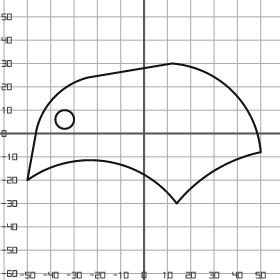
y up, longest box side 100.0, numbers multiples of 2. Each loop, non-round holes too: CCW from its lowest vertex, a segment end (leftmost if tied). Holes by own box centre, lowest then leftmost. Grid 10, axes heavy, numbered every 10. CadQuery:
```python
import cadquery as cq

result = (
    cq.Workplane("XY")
    .moveTo(14.0, -30.0)
    .threePointArc((30.0, -16.0), (50.0, -8.0))
    .threePointArc((38.0, 18.0), (12.0, 30.0))
    .lineTo(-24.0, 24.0)
    .threePointArc((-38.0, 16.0), (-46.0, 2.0))
    .lineTo(-50.0, -20.0)
    .threePointArc((-16.0, -12.0), (14.0, -30.0))
    .close()
    .moveTo(-34.0, 6.0)
    .circle(4.0)
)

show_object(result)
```